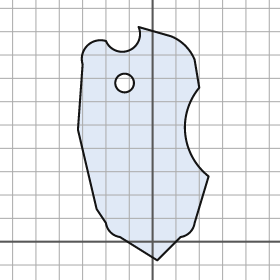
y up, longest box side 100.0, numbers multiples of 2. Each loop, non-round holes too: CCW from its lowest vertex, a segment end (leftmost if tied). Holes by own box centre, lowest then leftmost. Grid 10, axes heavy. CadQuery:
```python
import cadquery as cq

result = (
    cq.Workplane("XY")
    .moveTo(2.0, -8.0)
    .lineTo(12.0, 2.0)
    .threePointArc((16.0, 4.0), (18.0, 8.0))
    .lineTo(24.0, 28.0)
    .threePointArc((14.0, 46.0), (20.0, 66.0))
    .lineTo(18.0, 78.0)
    .threePointArc((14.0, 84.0), (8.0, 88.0))
    .lineTo(-6.0, 92.0)
    .threePointArc((-10.0, 82.0), (-20.0, 86.0))
    .threePointArc((-28.0, 84.0), (-30.0, 76.0))
    .lineTo(-32.0, 48.0)
    .lineTo(-24.0, 14.0)
    .lineTo(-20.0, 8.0)
    .threePointArc((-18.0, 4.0), (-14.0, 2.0))
    .close()
    .moveTo(-12.0, 68.0)
    .circle(4.0)
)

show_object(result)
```